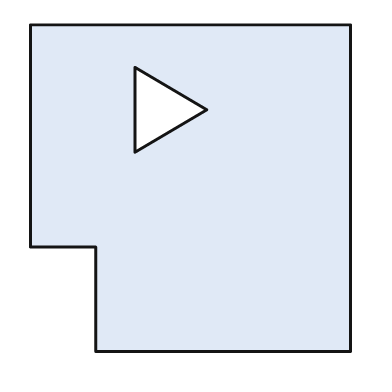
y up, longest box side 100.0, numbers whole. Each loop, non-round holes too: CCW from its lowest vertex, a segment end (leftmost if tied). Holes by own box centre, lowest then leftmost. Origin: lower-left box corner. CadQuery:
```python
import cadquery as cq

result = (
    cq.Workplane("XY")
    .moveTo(20.0, 0.0)
    .lineTo(98.0, 0.0)
    .lineTo(98.0, 100.0)
    .lineTo(0.0, 100.0)
    .lineTo(0.0, 32.0)
    .lineTo(20.0, 32.0)
    .close()
    .moveTo(32.0, 61.0)
    .lineTo(54.0, 74.0)
    .lineTo(32.0, 87.0)
    .close()
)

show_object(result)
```